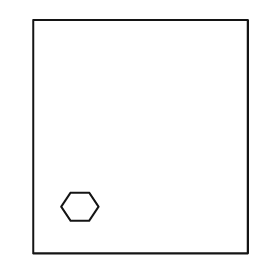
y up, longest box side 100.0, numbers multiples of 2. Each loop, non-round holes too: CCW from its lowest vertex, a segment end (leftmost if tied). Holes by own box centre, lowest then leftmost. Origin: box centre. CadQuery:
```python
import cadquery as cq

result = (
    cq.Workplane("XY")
    .moveTo(-46.0, -50.0)
    .lineTo(46.0, -50.0)
    .lineTo(46.0, 50.0)
    .lineTo(-46.0, 50.0)
    .close()
    .moveTo(-30.0, -36.0)
    .lineTo(-22.0, -36.0)
    .lineTo(-18.0, -30.0)
    .lineTo(-22.0, -24.0)
    .lineTo(-30.0, -24.0)
    .lineTo(-34.0, -30.0)
    .close()
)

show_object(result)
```